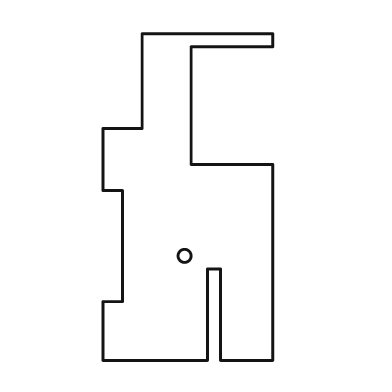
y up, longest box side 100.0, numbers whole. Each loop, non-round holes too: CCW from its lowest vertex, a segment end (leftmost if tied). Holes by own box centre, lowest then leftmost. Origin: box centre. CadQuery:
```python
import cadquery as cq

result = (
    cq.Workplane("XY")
    .moveTo(-26.0, -50.0)
    .lineTo(6.0, -50.0)
    .lineTo(6.0, -22.0)
    .lineTo(10.0, -22.0)
    .lineTo(10.0, -50.0)
    .lineTo(26.0, -50.0)
    .lineTo(26.0, 10.0)
    .lineTo(1.0, 10.0)
    .lineTo(1.0, 46.0)
    .lineTo(26.0, 46.0)
    .lineTo(26.0, 50.0)
    .lineTo(-14.0, 50.0)
    .lineTo(-14.0, 21.0)
    .lineTo(-26.0, 21.0)
    .lineTo(-26.0, 2.0)
    .lineTo(-20.0, 2.0)
    .lineTo(-20.0, -32.0)
    .lineTo(-26.0, -32.0)
    .close()
    .moveTo(-1.0, -18.0)
    .circle(2.0)
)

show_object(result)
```